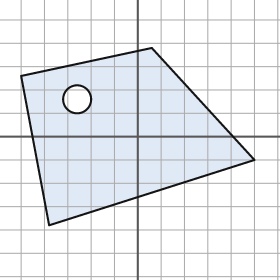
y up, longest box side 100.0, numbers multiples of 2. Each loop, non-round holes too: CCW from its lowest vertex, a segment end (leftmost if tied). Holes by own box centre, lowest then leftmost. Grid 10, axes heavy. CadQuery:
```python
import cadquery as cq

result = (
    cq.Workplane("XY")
    .moveTo(-38.0, -38.0)
    .lineTo(50.0, -10.0)
    .lineTo(6.0, 38.0)
    .lineTo(-50.0, 26.0)
    .close()
    .moveTo(-26.0, 16.0)
    .circle(6.0)
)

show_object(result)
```